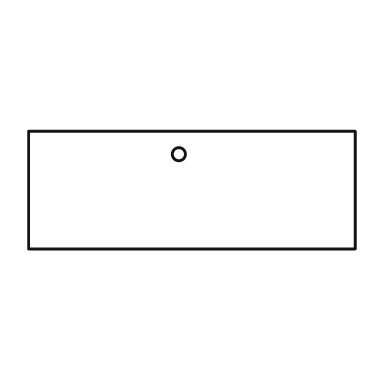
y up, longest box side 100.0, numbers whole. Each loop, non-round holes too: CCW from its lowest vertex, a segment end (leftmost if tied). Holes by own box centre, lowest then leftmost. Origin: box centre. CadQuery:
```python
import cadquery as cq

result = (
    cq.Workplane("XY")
    .moveTo(-50.0, -18.0)
    .lineTo(50.0, -18.0)
    .lineTo(50.0, 18.0)
    .lineTo(-50.0, 18.0)
    .close()
    .moveTo(-4.0, 11.0)
    .circle(2.0)
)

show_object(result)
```